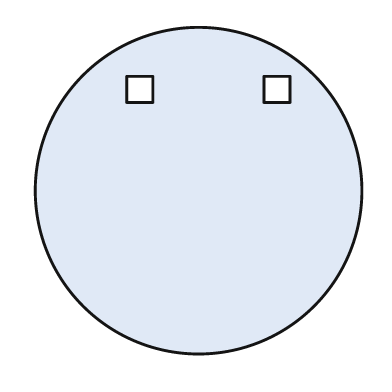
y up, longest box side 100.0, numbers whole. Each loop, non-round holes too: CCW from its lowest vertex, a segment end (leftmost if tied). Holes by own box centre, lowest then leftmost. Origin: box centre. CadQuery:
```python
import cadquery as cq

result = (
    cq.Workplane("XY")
    .moveTo(0.0, 0.0)
    .circle(50.0)
    .moveTo(-22.0, 27.0)
    .lineTo(-14.0, 27.0)
    .lineTo(-14.0, 35.0)
    .lineTo(-22.0, 35.0)
    .close()
    .moveTo(20.0, 27.0)
    .lineTo(28.0, 27.0)
    .lineTo(28.0, 35.0)
    .lineTo(20.0, 35.0)
    .close()
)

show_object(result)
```